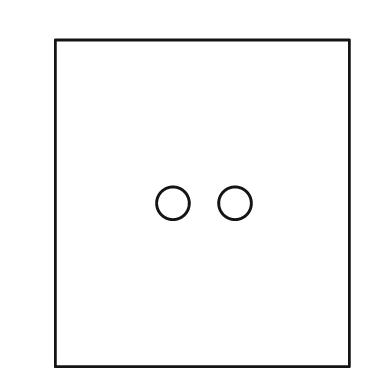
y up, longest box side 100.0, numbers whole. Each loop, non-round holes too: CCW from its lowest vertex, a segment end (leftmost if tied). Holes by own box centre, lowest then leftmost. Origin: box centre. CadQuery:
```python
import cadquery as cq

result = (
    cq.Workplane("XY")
    .moveTo(-45.0, -50.0)
    .lineTo(45.0, -50.0)
    .lineTo(45.0, 50.0)
    .lineTo(-45.0, 50.0)
    .close()
    .moveTo(-9.0, 0.0)
    .circle(5.0)
    .moveTo(10.0, 0.0)
    .circle(5.0)
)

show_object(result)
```